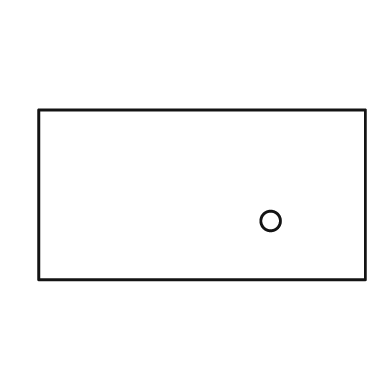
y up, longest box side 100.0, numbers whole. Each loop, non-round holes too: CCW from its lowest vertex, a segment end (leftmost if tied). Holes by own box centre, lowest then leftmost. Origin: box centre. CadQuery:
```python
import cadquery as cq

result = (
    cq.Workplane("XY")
    .moveTo(-50.0, -26.0)
    .lineTo(50.0, -26.0)
    .lineTo(50.0, 26.0)
    .lineTo(-50.0, 26.0)
    .close()
    .moveTo(21.0, -8.0)
    .circle(3.0)
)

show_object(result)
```